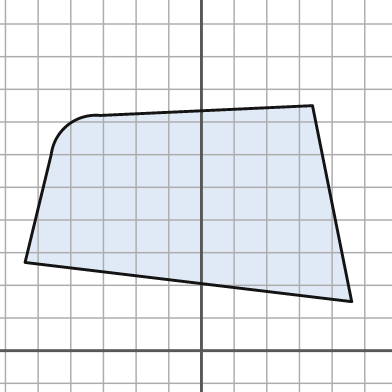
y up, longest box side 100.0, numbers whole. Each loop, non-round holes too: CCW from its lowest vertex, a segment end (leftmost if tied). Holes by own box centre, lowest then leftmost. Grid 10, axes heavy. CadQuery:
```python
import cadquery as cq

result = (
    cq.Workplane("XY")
    .moveTo(46.0, 15.0)
    .lineTo(34.0, 75.0)
    .lineTo(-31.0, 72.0)
    .threePointArc((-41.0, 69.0), (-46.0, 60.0))
    .lineTo(-54.0, 27.0)
    .close()
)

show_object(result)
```